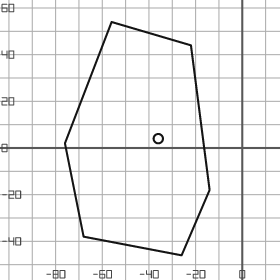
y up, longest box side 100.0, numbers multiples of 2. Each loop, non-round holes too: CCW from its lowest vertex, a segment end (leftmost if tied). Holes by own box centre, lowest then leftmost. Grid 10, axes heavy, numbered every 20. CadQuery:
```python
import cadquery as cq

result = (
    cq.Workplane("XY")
    .moveTo(-26.0, -46.0)
    .lineTo(-14.0, -18.0)
    .lineTo(-22.0, 44.0)
    .lineTo(-56.0, 54.0)
    .lineTo(-76.0, 2.0)
    .lineTo(-68.0, -38.0)
    .close()
    .moveTo(-36.0, 4.0)
    .circle(2.0)
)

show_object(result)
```